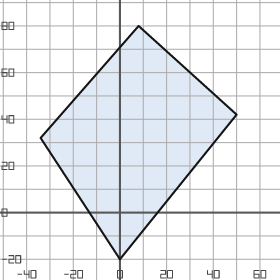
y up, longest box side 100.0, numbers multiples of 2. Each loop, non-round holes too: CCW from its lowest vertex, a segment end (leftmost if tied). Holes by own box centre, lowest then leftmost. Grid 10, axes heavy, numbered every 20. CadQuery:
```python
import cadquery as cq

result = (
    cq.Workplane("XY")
    .moveTo(0.0, -20.0)
    .lineTo(50.0, 42.0)
    .lineTo(8.0, 80.0)
    .lineTo(-34.0, 32.0)
    .close()
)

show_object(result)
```